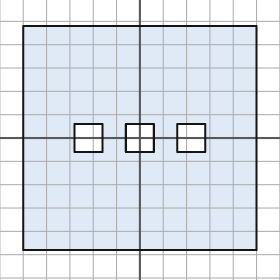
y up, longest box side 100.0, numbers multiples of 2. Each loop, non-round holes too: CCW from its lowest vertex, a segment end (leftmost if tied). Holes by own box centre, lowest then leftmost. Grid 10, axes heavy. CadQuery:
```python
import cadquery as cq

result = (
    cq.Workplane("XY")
    .moveTo(-50.0, -48.0)
    .lineTo(50.0, -48.0)
    .lineTo(50.0, 48.0)
    .lineTo(-50.0, 48.0)
    .close()
    .moveTo(-28.0, -6.0)
    .lineTo(-16.0, -6.0)
    .lineTo(-16.0, 6.0)
    .lineTo(-28.0, 6.0)
    .close()
    .moveTo(-6.0, -6.0)
    .lineTo(6.0, -6.0)
    .lineTo(6.0, 6.0)
    .lineTo(-6.0, 6.0)
    .close()
    .moveTo(16.0, -6.0)
    .lineTo(28.0, -6.0)
    .lineTo(28.0, 6.0)
    .lineTo(16.0, 6.0)
    .close()
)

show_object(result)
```